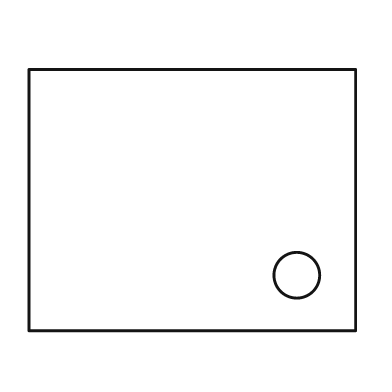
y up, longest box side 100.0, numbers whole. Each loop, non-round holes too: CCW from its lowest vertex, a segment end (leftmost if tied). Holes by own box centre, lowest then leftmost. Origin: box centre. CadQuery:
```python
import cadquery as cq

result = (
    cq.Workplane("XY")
    .moveTo(-50.0, -40.0)
    .lineTo(50.0, -40.0)
    .lineTo(50.0, 40.0)
    .lineTo(-50.0, 40.0)
    .close()
    .moveTo(32.0, -23.0)
    .circle(7.0)
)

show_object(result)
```